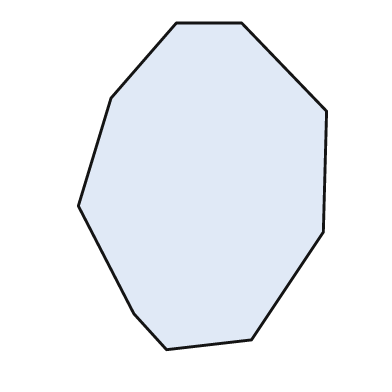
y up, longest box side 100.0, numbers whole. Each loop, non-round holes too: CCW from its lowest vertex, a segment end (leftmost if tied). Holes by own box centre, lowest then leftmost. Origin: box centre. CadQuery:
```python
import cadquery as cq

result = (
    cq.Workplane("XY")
    .moveTo(-11.0, -50.0)
    .lineTo(15.0, -47.0)
    .lineTo(37.0, -14.0)
    .lineTo(38.0, 23.0)
    .lineTo(12.0, 50.0)
    .lineTo(-8.0, 50.0)
    .lineTo(-28.0, 27.0)
    .lineTo(-38.0, -6.0)
    .lineTo(-21.0, -39.0)
    .close()
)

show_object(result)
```